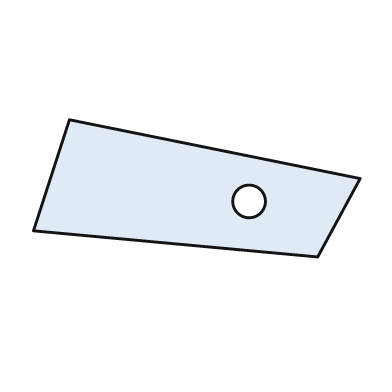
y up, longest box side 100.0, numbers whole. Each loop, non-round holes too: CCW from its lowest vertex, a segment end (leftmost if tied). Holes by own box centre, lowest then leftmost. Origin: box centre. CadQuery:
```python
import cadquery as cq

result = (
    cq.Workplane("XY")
    .moveTo(37.0, -21.0)
    .lineTo(50.0, 3.0)
    .lineTo(-39.0, 21.0)
    .lineTo(-50.0, -13.0)
    .close()
    .moveTo(16.0, -4.0)
    .circle(5.0)
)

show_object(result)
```